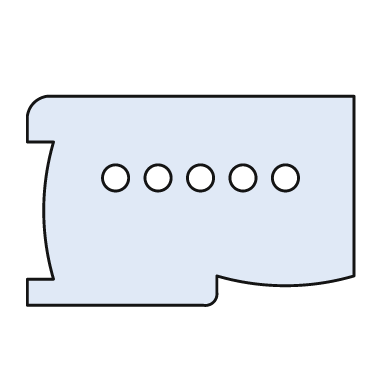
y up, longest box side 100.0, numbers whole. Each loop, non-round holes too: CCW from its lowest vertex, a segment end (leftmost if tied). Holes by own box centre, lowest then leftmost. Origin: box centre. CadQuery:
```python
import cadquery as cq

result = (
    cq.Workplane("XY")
    .moveTo(-50.0, -32.0)
    .lineTo(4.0, -32.0)
    .threePointArc((7.0, -31.0), (8.0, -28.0))
    .lineTo(8.0, -23.0)
    .threePointArc((29.0, -26.0), (50.0, -23.0))
    .lineTo(50.0, 32.0)
    .lineTo(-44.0, 32.0)
    .threePointArc((-48.0, 30.0), (-50.0, 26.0))
    .lineTo(-50.0, 18.0)
    .lineTo(-42.0, 18.0)
    .threePointArc((-45.0, -3.0), (-42.0, -24.0))
    .lineTo(-50.0, -24.0)
    .close()
    .moveTo(-23.0, 7.0)
    .circle(4.0)
    .moveTo(-10.0, 7.0)
    .circle(4.0)
    .moveTo(3.0, 7.0)
    .circle(4.0)
    .moveTo(16.0, 7.0)
    .circle(4.0)
    .moveTo(29.0, 7.0)
    .circle(4.0)
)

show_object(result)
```